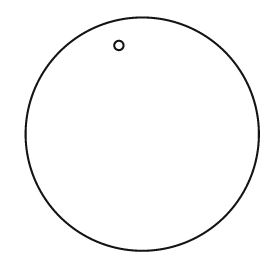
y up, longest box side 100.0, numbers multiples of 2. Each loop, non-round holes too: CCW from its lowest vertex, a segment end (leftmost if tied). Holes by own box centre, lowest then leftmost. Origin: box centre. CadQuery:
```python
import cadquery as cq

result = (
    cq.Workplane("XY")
    .moveTo(0.0, 0.0)
    .circle(50.0)
    .moveTo(-10.0, 38.0)
    .circle(2.0)
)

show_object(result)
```